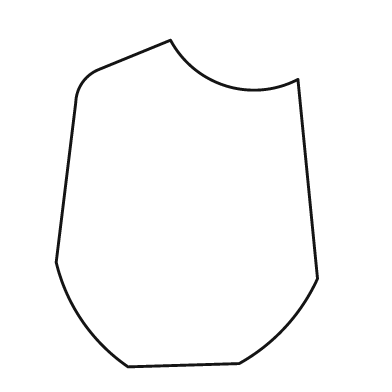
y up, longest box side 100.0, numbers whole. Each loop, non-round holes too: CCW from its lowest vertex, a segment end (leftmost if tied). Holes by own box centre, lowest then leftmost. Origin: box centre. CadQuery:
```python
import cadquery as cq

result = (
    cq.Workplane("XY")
    .moveTo(-18.0, -50.0)
    .lineTo(16.0, -49.0)
    .threePointArc((30.0, -38.0), (40.0, -23.0))
    .lineTo(34.0, 38.0)
    .threePointArc((12.0, 36.0), (-5.0, 50.0))
    .lineTo(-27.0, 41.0)
    .threePointArc((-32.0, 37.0), (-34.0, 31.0))
    .lineTo(-40.0, -18.0)
    .threePointArc((-32.0, -36.0), (-18.0, -50.0))
    .close()
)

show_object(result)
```